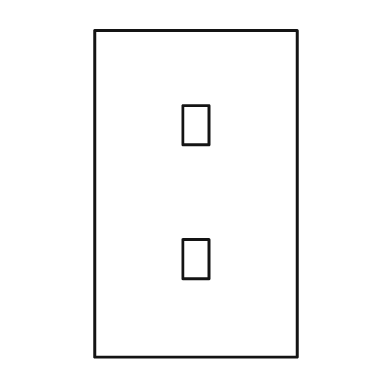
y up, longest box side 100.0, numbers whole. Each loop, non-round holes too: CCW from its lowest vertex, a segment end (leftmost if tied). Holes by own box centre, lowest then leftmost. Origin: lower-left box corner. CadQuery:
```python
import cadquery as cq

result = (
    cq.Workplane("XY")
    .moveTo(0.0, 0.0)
    .lineTo(62.0, 0.0)
    .lineTo(62.0, 100.0)
    .lineTo(0.0, 100.0)
    .close()
    .moveTo(27.0, 24.0)
    .lineTo(35.0, 24.0)
    .lineTo(35.0, 36.0)
    .lineTo(27.0, 36.0)
    .close()
    .moveTo(27.0, 65.0)
    .lineTo(35.0, 65.0)
    .lineTo(35.0, 77.0)
    .lineTo(27.0, 77.0)
    .close()
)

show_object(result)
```